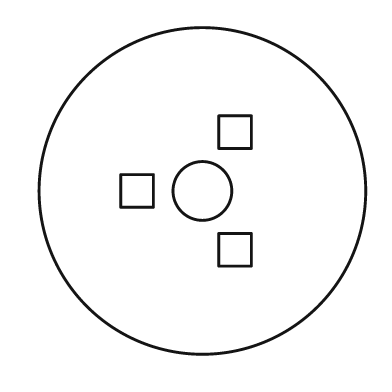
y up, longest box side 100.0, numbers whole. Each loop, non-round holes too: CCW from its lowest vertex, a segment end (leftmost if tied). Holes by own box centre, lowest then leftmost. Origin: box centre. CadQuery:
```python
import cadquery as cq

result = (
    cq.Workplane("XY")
    .moveTo(0.0, 0.0)
    .circle(50.0)
    .moveTo(5.0, -23.0)
    .lineTo(15.0, -23.0)
    .lineTo(15.0, -13.0)
    .lineTo(5.0, -13.0)
    .close()
    .moveTo(-25.0, -5.0)
    .lineTo(-15.0, -5.0)
    .lineTo(-15.0, 5.0)
    .lineTo(-25.0, 5.0)
    .close()
    .moveTo(0.0, 0.0)
    .circle(9.0)
    .moveTo(5.0, 13.0)
    .lineTo(15.0, 13.0)
    .lineTo(15.0, 23.0)
    .lineTo(5.0, 23.0)
    .close()
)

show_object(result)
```